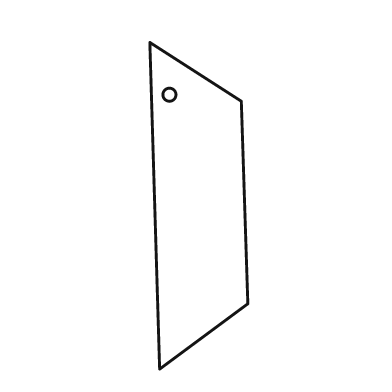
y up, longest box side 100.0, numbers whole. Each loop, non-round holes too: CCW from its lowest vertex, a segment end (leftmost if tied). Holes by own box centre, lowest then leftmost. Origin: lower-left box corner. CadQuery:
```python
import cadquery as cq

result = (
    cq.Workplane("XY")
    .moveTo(3.0, 0.0)
    .lineTo(30.0, 20.0)
    .lineTo(28.0, 82.0)
    .lineTo(0.0, 100.0)
    .close()
    .moveTo(6.0, 84.0)
    .circle(2.0)
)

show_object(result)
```